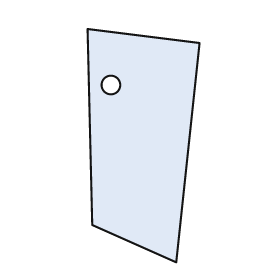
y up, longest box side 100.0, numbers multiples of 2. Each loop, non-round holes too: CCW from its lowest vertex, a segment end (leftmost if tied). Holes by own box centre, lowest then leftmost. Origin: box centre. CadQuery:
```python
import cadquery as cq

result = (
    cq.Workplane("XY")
    .moveTo(14.0, -50.0)
    .lineTo(24.0, 44.0)
    .lineTo(-24.0, 50.0)
    .lineTo(-22.0, -34.0)
    .close()
    .moveTo(-14.0, 26.0)
    .circle(4.0)
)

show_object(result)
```